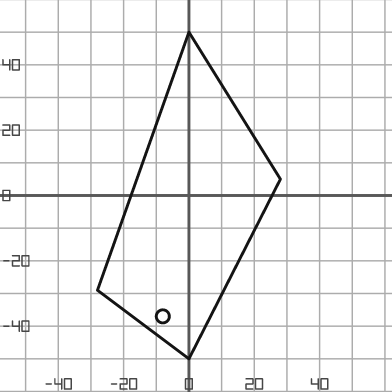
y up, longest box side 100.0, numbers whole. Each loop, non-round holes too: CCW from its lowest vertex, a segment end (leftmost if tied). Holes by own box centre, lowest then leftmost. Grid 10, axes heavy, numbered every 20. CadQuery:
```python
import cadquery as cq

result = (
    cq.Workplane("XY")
    .moveTo(0.0, -50.0)
    .lineTo(28.0, 5.0)
    .lineTo(0.0, 50.0)
    .lineTo(-28.0, -29.0)
    .close()
    .moveTo(-8.0, -37.0)
    .circle(2.0)
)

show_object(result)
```